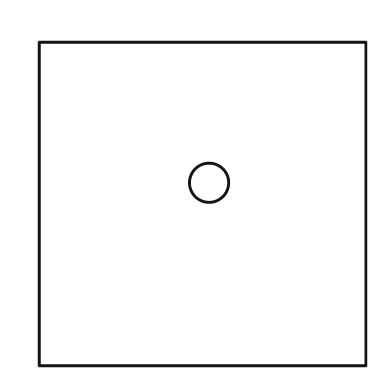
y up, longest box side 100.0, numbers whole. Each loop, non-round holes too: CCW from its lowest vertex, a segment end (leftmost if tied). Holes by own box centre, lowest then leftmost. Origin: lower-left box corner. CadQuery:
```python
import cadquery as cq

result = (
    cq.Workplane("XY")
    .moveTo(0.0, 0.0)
    .lineTo(100.0, 0.0)
    .lineTo(100.0, 99.0)
    .lineTo(0.0, 99.0)
    .close()
    .moveTo(52.0, 56.0)
    .circle(6.0)
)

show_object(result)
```